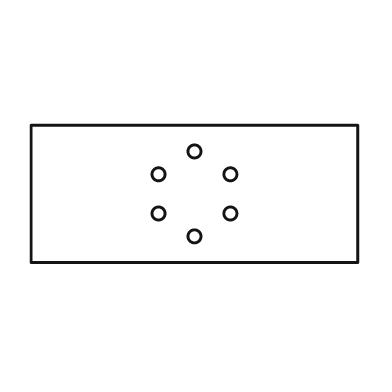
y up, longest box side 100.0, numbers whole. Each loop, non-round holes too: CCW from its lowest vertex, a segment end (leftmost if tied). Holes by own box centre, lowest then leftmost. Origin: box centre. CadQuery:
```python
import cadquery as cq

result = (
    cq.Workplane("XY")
    .moveTo(-50.0, -21.0)
    .lineTo(50.0, -21.0)
    .lineTo(50.0, 21.0)
    .lineTo(-50.0, 21.0)
    .close()
    .moveTo(0.0, -13.0)
    .circle(2.0)
    .moveTo(-11.0, -6.0)
    .circle(2.0)
    .moveTo(11.0, -6.0)
    .circle(2.0)
    .moveTo(-11.0, 6.0)
    .circle(2.0)
    .moveTo(11.0, 6.0)
    .circle(2.0)
    .moveTo(0.0, 13.0)
    .circle(2.0)
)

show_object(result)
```